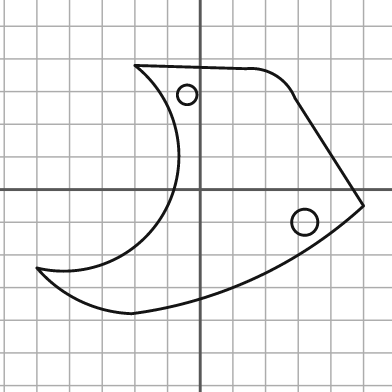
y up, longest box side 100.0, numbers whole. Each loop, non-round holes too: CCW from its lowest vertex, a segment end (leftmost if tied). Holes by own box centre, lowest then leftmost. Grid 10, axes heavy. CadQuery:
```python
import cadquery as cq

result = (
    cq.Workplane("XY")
    .moveTo(-21.0, -38.0)
    .threePointArc((17.0, -27.0), (50.0, -5.0))
    .lineTo(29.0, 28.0)
    .threePointArc((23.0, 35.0), (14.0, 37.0))
    .lineTo(-20.0, 38.0)
    .threePointArc((-10.0, -5.0), (-50.0, -24.0))
    .threePointArc((-37.0, -34.0), (-21.0, -38.0))
    .close()
    .moveTo(32.0, -10.0)
    .circle(4.0)
    .moveTo(-4.0, 29.0)
    .circle(3.0)
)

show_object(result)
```